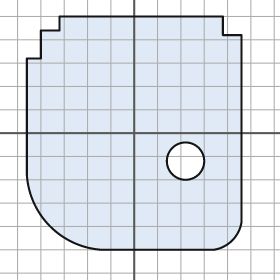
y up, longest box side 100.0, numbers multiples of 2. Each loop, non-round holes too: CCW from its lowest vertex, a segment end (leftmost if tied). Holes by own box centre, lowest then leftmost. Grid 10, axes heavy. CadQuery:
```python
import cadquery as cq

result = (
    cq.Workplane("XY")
    .moveTo(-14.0, -50.0)
    .lineTo(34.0, -50.0)
    .threePointArc((42.0, -46.0), (46.0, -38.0))
    .lineTo(46.0, 42.0)
    .lineTo(38.0, 42.0)
    .lineTo(38.0, 50.0)
    .lineTo(-32.0, 50.0)
    .lineTo(-32.0, 44.0)
    .lineTo(-40.0, 44.0)
    .lineTo(-40.0, 32.0)
    .lineTo(-46.0, 32.0)
    .lineTo(-46.0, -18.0)
    .threePointArc((-36.0, -40.0), (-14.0, -50.0))
    .close()
    .moveTo(22.0, -12.0)
    .circle(8.0)
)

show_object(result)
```